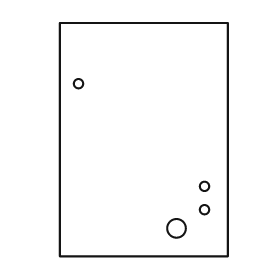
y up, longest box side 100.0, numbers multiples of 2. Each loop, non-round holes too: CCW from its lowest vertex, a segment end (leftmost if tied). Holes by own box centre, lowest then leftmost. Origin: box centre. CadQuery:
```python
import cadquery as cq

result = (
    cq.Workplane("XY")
    .moveTo(-36.0, -50.0)
    .lineTo(36.0, -50.0)
    .lineTo(36.0, 50.0)
    .lineTo(-36.0, 50.0)
    .close()
    .moveTo(14.0, -38.0)
    .circle(4.0)
    .moveTo(26.0, -30.0)
    .circle(2.0)
    .moveTo(26.0, -20.0)
    .circle(2.0)
    .moveTo(-28.0, 24.0)
    .circle(2.0)
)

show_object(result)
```